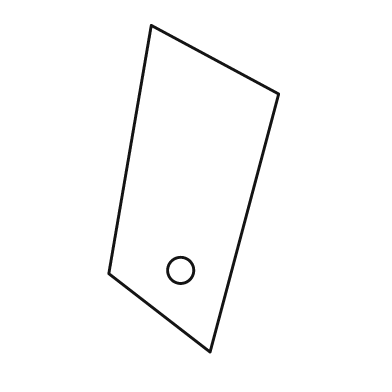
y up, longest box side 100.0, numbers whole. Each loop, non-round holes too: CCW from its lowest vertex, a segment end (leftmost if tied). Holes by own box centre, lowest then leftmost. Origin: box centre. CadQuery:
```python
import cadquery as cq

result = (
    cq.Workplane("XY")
    .moveTo(5.0, -50.0)
    .lineTo(26.0, 29.0)
    .lineTo(-13.0, 50.0)
    .lineTo(-26.0, -26.0)
    .close()
    .moveTo(-4.0, -25.0)
    .circle(4.0)
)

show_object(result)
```